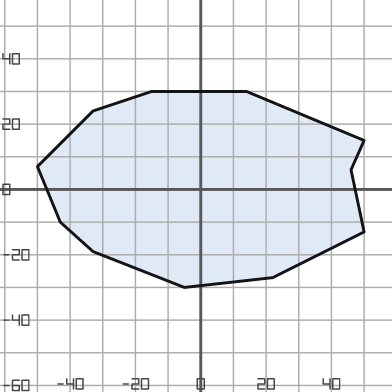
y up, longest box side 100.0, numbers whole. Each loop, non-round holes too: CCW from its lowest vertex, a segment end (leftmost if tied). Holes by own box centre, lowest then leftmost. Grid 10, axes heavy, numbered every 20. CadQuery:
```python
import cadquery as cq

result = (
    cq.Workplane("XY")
    .moveTo(-5.0, -30.0)
    .lineTo(22.0, -27.0)
    .lineTo(50.0, -13.0)
    .lineTo(46.0, 6.0)
    .lineTo(50.0, 15.0)
    .lineTo(14.0, 30.0)
    .lineTo(-15.0, 30.0)
    .lineTo(-33.0, 24.0)
    .lineTo(-50.0, 7.0)
    .lineTo(-43.0, -10.0)
    .lineTo(-33.0, -19.0)
    .close()
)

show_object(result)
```